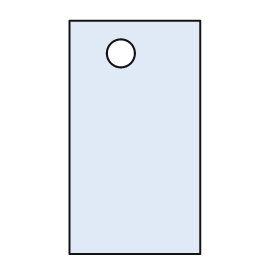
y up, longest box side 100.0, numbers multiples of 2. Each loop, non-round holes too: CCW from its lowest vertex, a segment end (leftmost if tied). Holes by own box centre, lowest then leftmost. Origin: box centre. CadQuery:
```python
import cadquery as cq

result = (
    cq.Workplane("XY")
    .moveTo(-28.0, -50.0)
    .lineTo(28.0, -50.0)
    .lineTo(28.0, 50.0)
    .lineTo(-28.0, 50.0)
    .close()
    .moveTo(-6.0, 36.0)
    .circle(6.0)
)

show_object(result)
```